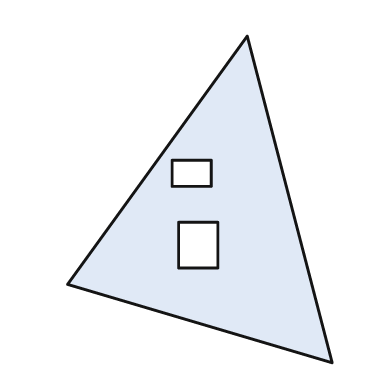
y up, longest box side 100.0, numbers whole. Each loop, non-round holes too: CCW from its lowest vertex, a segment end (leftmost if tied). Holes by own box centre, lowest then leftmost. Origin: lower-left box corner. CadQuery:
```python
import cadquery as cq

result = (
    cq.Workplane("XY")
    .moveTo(81.0, 0.0)
    .lineTo(55.0, 100.0)
    .lineTo(0.0, 24.0)
    .close()
    .moveTo(34.0, 29.0)
    .lineTo(46.0, 29.0)
    .lineTo(46.0, 43.0)
    .lineTo(34.0, 43.0)
    .close()
    .moveTo(32.0, 54.0)
    .lineTo(44.0, 54.0)
    .lineTo(44.0, 62.0)
    .lineTo(32.0, 62.0)
    .close()
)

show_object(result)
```